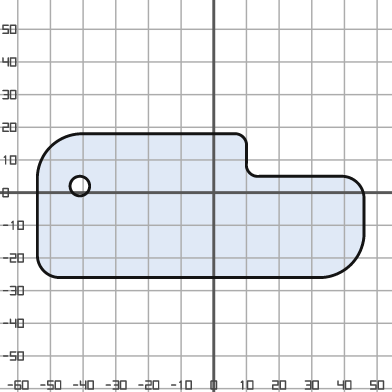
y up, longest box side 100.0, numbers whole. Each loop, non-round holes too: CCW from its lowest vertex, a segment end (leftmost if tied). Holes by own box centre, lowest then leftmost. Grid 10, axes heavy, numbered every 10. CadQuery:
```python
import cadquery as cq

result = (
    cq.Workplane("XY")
    .moveTo(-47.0, -26.0)
    .lineTo(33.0, -26.0)
    .threePointArc((42.0, -22.0), (46.0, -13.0))
    .lineTo(46.0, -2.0)
    .threePointArc((44.0, 3.0), (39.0, 5.0))
    .lineTo(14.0, 5.0)
    .threePointArc((11.0, 6.0), (10.0, 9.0))
    .lineTo(10.0, 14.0)
    .threePointArc((9.0, 17.0), (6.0, 18.0))
    .lineTo(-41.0, 18.0)
    .threePointArc((-50.0, 14.0), (-54.0, 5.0))
    .lineTo(-54.0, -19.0)
    .threePointArc((-52.0, -24.0), (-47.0, -26.0))
    .close()
    .moveTo(-41.0, 2.0)
    .circle(3.0)
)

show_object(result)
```